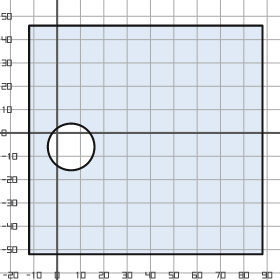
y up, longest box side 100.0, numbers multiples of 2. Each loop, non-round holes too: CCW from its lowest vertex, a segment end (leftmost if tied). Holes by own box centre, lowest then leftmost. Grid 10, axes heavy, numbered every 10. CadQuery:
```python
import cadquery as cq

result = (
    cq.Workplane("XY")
    .moveTo(-12.0, -52.0)
    .lineTo(88.0, -52.0)
    .lineTo(88.0, 46.0)
    .lineTo(-12.0, 46.0)
    .close()
    .moveTo(6.0, -6.0)
    .circle(10.0)
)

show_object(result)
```